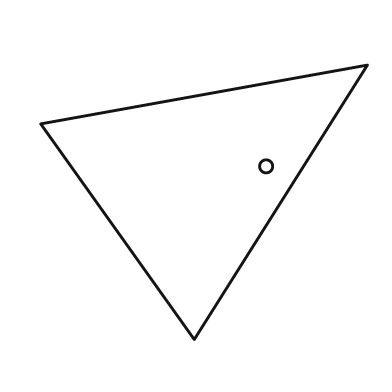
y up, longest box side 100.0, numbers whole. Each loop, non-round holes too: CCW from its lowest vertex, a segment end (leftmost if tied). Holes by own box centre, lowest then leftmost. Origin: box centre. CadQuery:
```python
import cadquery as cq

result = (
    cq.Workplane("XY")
    .moveTo(-3.0, -42.0)
    .lineTo(50.0, 42.0)
    .lineTo(-50.0, 24.0)
    .close()
    .moveTo(19.0, 11.0)
    .circle(2.0)
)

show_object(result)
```